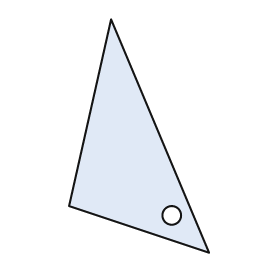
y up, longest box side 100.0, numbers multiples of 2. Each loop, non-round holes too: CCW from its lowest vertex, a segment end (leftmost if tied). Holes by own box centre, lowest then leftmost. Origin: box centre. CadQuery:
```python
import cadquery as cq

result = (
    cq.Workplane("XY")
    .moveTo(30.0, -50.0)
    .lineTo(-12.0, 50.0)
    .lineTo(-30.0, -30.0)
    .close()
    .moveTo(14.0, -34.0)
    .circle(4.0)
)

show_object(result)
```